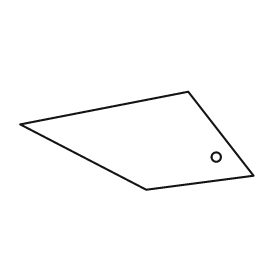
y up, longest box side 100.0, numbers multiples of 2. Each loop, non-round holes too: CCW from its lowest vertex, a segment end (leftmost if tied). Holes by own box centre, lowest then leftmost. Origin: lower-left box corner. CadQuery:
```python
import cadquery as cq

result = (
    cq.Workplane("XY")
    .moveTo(54.0, 0.0)
    .lineTo(100.0, 6.0)
    .lineTo(72.0, 42.0)
    .lineTo(0.0, 28.0)
    .close()
    .moveTo(84.0, 14.0)
    .circle(2.0)
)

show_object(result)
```